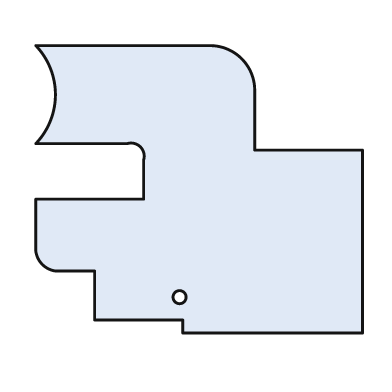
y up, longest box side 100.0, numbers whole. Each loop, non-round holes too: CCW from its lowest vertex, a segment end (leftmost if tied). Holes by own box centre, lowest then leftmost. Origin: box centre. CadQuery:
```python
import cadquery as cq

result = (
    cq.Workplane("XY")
    .moveTo(-5.0, -44.0)
    .lineTo(50.0, -44.0)
    .lineTo(50.0, 12.0)
    .lineTo(17.0, 12.0)
    .lineTo(17.0, 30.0)
    .threePointArc((13.0, 40.0), (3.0, 44.0))
    .lineTo(-50.0, 44.0)
    .threePointArc((-44.0, 29.0), (-50.0, 14.0))
    .lineTo(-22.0, 14.0)
    .threePointArc((-18.0, 13.0), (-17.0, 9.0))
    .lineTo(-17.0, -3.0)
    .lineTo(-50.0, -3.0)
    .lineTo(-50.0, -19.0)
    .threePointArc((-48.0, -23.0), (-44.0, -25.0))
    .lineTo(-32.0, -25.0)
    .lineTo(-32.0, -40.0)
    .lineTo(-5.0, -40.0)
    .close()
    .moveTo(-6.0, -33.0)
    .circle(2.0)
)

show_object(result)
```